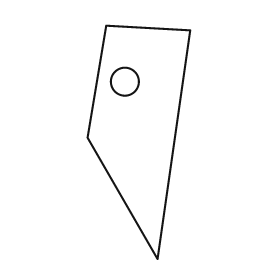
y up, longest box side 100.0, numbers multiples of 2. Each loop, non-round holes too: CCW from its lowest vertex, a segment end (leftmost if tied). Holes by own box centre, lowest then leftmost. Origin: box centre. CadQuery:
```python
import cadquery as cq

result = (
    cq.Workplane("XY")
    .moveTo(8.0, -50.0)
    .lineTo(22.0, 48.0)
    .lineTo(-14.0, 50.0)
    .lineTo(-22.0, 2.0)
    .close()
    .moveTo(-6.0, 26.0)
    .circle(6.0)
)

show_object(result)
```